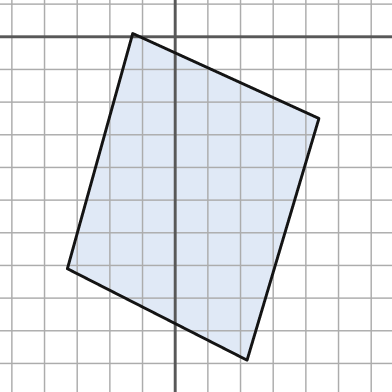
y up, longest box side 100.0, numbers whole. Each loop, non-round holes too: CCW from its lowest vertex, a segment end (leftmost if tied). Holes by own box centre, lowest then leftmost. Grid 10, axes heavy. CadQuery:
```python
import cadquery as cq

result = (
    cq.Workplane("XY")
    .moveTo(22.0, -99.0)
    .lineTo(44.0, -25.0)
    .lineTo(-13.0, 1.0)
    .lineTo(-33.0, -71.0)
    .close()
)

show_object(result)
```